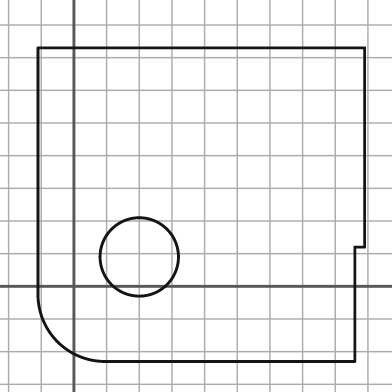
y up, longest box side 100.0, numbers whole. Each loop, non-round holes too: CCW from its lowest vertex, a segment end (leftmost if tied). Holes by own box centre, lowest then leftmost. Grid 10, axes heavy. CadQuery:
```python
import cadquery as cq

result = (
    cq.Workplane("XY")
    .moveTo(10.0, -23.0)
    .lineTo(86.0, -23.0)
    .lineTo(86.0, 12.0)
    .lineTo(89.0, 12.0)
    .lineTo(89.0, 73.0)
    .lineTo(-11.0, 73.0)
    .lineTo(-11.0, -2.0)
    .threePointArc((-5.0, -17.0), (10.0, -23.0))
    .close()
    .moveTo(20.0, 9.0)
    .circle(12.0)
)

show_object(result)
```